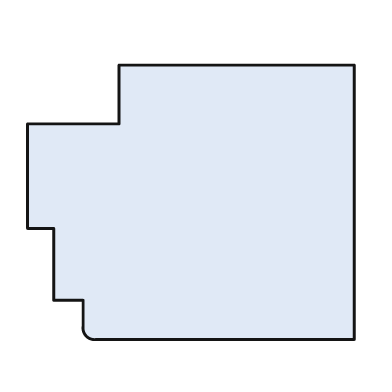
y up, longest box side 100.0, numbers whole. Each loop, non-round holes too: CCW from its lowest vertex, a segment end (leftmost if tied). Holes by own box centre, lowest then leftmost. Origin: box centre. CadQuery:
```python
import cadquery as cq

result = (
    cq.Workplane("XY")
    .moveTo(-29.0, -42.0)
    .lineTo(50.0, -42.0)
    .lineTo(50.0, 42.0)
    .lineTo(-22.0, 42.0)
    .lineTo(-22.0, 24.0)
    .lineTo(-50.0, 24.0)
    .lineTo(-50.0, -8.0)
    .lineTo(-42.0, -8.0)
    .lineTo(-42.0, -30.0)
    .lineTo(-33.0, -30.0)
    .lineTo(-33.0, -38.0)
    .threePointArc((-32.0, -41.0), (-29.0, -42.0))
    .close()
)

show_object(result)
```